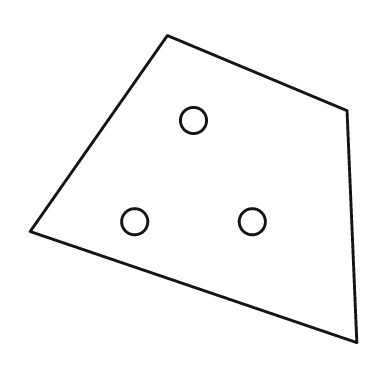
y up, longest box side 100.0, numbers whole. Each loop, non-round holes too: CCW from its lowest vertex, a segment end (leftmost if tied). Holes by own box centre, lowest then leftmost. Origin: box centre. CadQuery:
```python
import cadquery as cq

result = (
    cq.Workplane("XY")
    .moveTo(50.0, -47.0)
    .lineTo(47.0, 24.0)
    .lineTo(-8.0, 47.0)
    .lineTo(-50.0, -13.0)
    .close()
    .moveTo(-18.0, -10.0)
    .circle(4.0)
    .moveTo(18.0, -10.0)
    .circle(4.0)
    .moveTo(0.0, 21.0)
    .circle(4.0)
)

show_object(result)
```